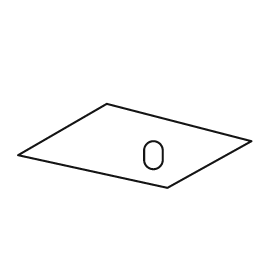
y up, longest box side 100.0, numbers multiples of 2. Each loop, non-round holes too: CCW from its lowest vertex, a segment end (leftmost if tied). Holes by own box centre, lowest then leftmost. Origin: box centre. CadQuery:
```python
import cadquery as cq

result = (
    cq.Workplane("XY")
    .moveTo(14.0, -18.0)
    .lineTo(50.0, 2.0)
    .lineTo(-12.0, 18.0)
    .lineTo(-50.0, -4.0)
    .close()
    .moveTo(4.0, -6.0)
    .threePointArc((8.0, -10.0), (12.0, -6.0))
    .lineTo(12.0, -2.0)
    .threePointArc((8.0, 2.0), (4.0, -2.0))
    .close()
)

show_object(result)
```